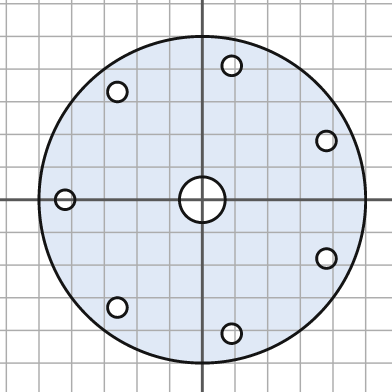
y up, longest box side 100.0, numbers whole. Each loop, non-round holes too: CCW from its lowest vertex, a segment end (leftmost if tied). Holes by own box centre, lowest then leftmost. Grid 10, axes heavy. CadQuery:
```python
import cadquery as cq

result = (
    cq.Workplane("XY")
    .moveTo(0.0, 0.0)
    .circle(50.0)
    .moveTo(9.0, -41.0)
    .circle(3.0)
    .moveTo(-26.0, -33.0)
    .circle(3.0)
    .moveTo(38.0, -18.0)
    .circle(3.0)
    .moveTo(-42.0, 0.0)
    .circle(3.0)
    .moveTo(0.0, 0.0)
    .circle(7.0)
    .moveTo(38.0, 18.0)
    .circle(3.0)
    .moveTo(-26.0, 33.0)
    .circle(3.0)
    .moveTo(9.0, 41.0)
    .circle(3.0)
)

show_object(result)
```